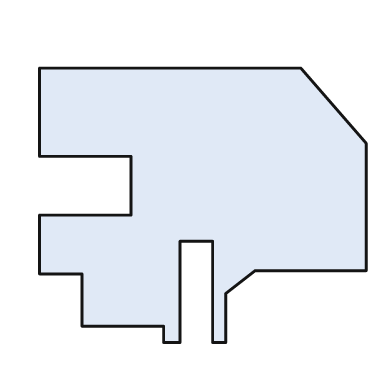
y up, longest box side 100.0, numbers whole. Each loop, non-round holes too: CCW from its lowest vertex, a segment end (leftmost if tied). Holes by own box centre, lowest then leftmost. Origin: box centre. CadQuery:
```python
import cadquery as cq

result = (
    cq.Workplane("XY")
    .moveTo(-12.0, -42.0)
    .lineTo(-7.0, -42.0)
    .lineTo(-7.0, -11.0)
    .lineTo(3.0, -11.0)
    .lineTo(3.0, -42.0)
    .lineTo(7.0, -42.0)
    .lineTo(7.0, -27.0)
    .lineTo(16.0, -20.0)
    .lineTo(50.0, -20.0)
    .lineTo(50.0, 19.0)
    .lineTo(30.0, 42.0)
    .lineTo(-50.0, 42.0)
    .lineTo(-50.0, 15.0)
    .lineTo(-22.0, 15.0)
    .lineTo(-22.0, -3.0)
    .lineTo(-50.0, -3.0)
    .lineTo(-50.0, -21.0)
    .lineTo(-37.0, -21.0)
    .lineTo(-37.0, -37.0)
    .lineTo(-12.0, -37.0)
    .close()
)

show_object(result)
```